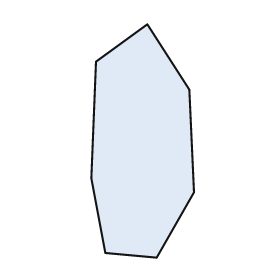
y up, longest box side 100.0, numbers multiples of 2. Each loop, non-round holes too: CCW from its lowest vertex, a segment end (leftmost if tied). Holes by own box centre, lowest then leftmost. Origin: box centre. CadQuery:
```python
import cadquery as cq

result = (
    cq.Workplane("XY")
    .moveTo(6.0, -50.0)
    .lineTo(22.0, -22.0)
    .lineTo(20.0, 22.0)
    .lineTo(2.0, 50.0)
    .lineTo(-20.0, 34.0)
    .lineTo(-22.0, -16.0)
    .lineTo(-16.0, -48.0)
    .close()
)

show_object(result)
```